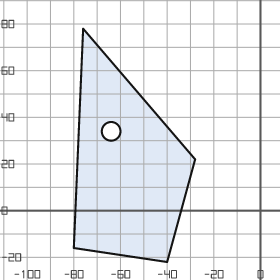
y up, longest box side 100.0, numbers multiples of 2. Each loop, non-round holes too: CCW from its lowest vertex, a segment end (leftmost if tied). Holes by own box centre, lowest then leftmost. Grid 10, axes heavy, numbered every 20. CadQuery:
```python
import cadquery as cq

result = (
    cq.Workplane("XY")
    .moveTo(-40.0, -22.0)
    .lineTo(-28.0, 22.0)
    .lineTo(-76.0, 78.0)
    .lineTo(-80.0, -16.0)
    .close()
    .moveTo(-64.0, 34.0)
    .circle(4.0)
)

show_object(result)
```